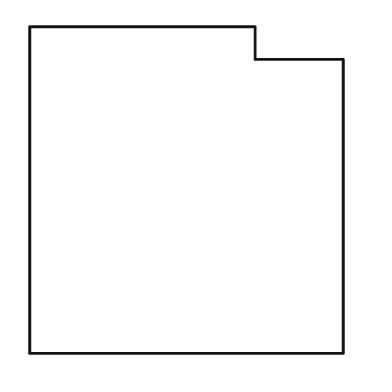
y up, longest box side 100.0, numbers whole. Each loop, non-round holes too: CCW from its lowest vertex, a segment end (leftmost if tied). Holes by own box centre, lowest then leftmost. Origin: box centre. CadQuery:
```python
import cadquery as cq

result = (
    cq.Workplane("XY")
    .moveTo(-48.0, -50.0)
    .lineTo(48.0, -50.0)
    .lineTo(48.0, 40.0)
    .lineTo(21.0, 40.0)
    .lineTo(21.0, 50.0)
    .lineTo(-48.0, 50.0)
    .close()
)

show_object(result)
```